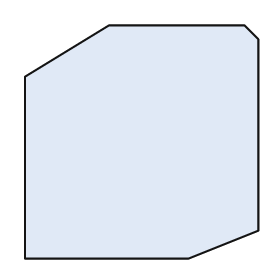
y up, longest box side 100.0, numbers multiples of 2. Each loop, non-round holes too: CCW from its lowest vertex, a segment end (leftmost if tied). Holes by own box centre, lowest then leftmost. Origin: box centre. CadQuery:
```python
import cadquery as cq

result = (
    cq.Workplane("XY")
    .moveTo(-50.0, -50.0)
    .lineTo(20.0, -50.0)
    .lineTo(50.0, -38.0)
    .lineTo(50.0, 44.0)
    .lineTo(44.0, 50.0)
    .lineTo(-14.0, 50.0)
    .lineTo(-50.0, 28.0)
    .close()
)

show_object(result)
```